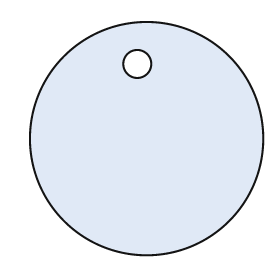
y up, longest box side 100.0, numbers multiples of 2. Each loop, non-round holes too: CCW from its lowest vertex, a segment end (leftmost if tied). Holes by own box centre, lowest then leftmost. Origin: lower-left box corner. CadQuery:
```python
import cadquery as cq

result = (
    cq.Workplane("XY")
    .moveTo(50.0, 50.0)
    .circle(50.0)
    .moveTo(46.0, 82.0)
    .circle(6.0)
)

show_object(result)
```